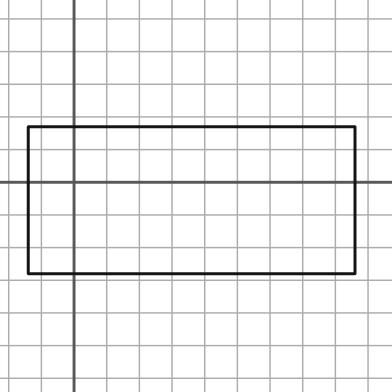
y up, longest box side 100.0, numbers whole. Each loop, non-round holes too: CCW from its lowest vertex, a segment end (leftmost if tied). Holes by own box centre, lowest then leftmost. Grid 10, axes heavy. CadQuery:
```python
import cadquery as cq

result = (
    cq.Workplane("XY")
    .moveTo(-14.0, -28.0)
    .lineTo(86.0, -28.0)
    .lineTo(86.0, 17.0)
    .lineTo(-14.0, 17.0)
    .close()
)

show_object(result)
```